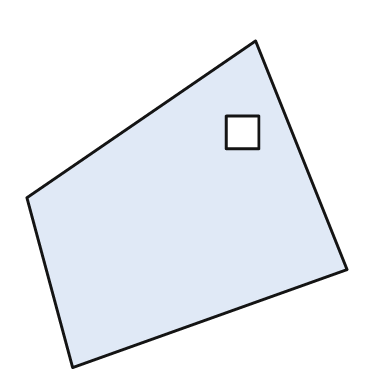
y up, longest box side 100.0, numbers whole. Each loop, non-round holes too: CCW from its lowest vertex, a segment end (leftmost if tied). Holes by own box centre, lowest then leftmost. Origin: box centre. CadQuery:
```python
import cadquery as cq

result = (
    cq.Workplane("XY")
    .moveTo(-35.0, -50.0)
    .lineTo(49.0, -20.0)
    .lineTo(21.0, 50.0)
    .lineTo(-49.0, 2.0)
    .close()
    .moveTo(12.0, 17.0)
    .lineTo(22.0, 17.0)
    .lineTo(22.0, 27.0)
    .lineTo(12.0, 27.0)
    .close()
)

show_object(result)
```